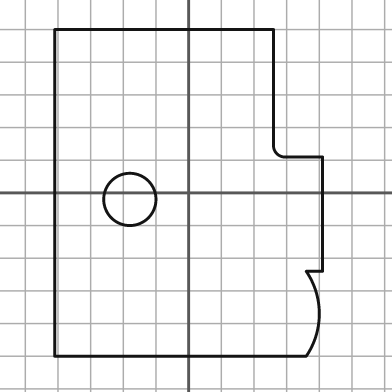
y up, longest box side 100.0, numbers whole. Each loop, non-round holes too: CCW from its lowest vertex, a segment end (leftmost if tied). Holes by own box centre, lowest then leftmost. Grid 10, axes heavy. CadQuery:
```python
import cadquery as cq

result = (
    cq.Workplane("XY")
    .moveTo(-41.0, -50.0)
    .lineTo(36.0, -50.0)
    .threePointArc((40.0, -37.0), (36.0, -24.0))
    .lineTo(41.0, -24.0)
    .lineTo(41.0, 11.0)
    .lineTo(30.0, 11.0)
    .threePointArc((27.0, 12.0), (26.0, 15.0))
    .lineTo(26.0, 50.0)
    .lineTo(-41.0, 50.0)
    .close()
    .moveTo(-18.0, -2.0)
    .circle(8.0)
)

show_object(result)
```